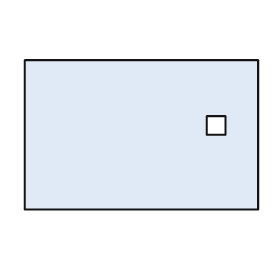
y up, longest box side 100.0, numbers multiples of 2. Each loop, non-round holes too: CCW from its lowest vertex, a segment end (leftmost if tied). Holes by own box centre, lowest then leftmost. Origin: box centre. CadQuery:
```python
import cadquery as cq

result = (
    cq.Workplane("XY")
    .moveTo(-50.0, -32.0)
    .lineTo(50.0, -32.0)
    .lineTo(50.0, 32.0)
    .lineTo(-50.0, 32.0)
    .close()
    .moveTo(28.0, 0.0)
    .lineTo(36.0, 0.0)
    .lineTo(36.0, 8.0)
    .lineTo(28.0, 8.0)
    .close()
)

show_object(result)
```